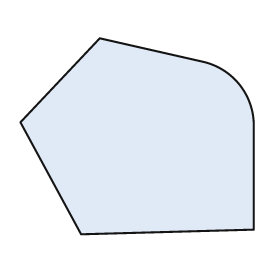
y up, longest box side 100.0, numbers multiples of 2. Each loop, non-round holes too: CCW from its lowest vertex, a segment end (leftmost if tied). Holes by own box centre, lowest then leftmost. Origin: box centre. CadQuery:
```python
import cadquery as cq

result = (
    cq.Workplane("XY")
    .moveTo(-24.0, -42.0)
    .lineTo(50.0, -40.0)
    .lineTo(50.0, 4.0)
    .threePointArc((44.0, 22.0), (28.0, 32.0))
    .lineTo(-16.0, 42.0)
    .lineTo(-50.0, 6.0)
    .close()
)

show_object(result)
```